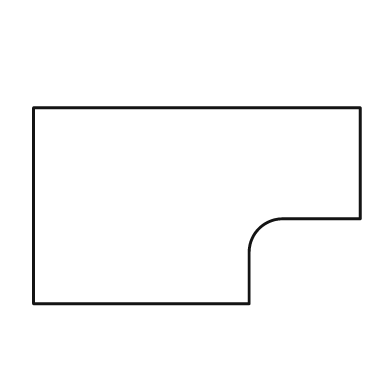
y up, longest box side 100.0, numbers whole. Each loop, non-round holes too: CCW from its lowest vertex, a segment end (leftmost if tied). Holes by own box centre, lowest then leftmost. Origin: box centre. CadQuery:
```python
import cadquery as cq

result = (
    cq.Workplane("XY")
    .moveTo(-50.0, -30.0)
    .lineTo(16.0, -30.0)
    .lineTo(16.0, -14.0)
    .threePointArc((19.0, -7.0), (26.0, -4.0))
    .lineTo(50.0, -4.0)
    .lineTo(50.0, 30.0)
    .lineTo(-50.0, 30.0)
    .close()
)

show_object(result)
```